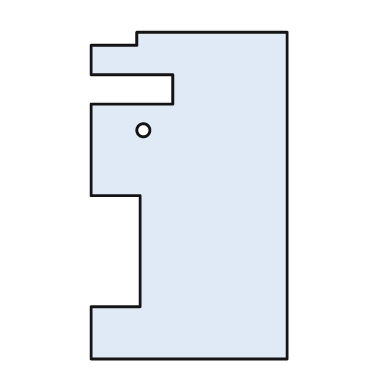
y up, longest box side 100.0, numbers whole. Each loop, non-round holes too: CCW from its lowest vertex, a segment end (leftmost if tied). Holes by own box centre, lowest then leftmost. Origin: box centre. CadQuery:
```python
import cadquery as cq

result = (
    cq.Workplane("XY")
    .moveTo(-30.0, -50.0)
    .lineTo(30.0, -50.0)
    .lineTo(30.0, 50.0)
    .lineTo(-16.0, 50.0)
    .lineTo(-16.0, 46.0)
    .lineTo(-30.0, 46.0)
    .lineTo(-30.0, 37.0)
    .lineTo(-5.0, 37.0)
    .lineTo(-5.0, 28.0)
    .lineTo(-30.0, 28.0)
    .lineTo(-30.0, 0.0)
    .lineTo(-15.0, 0.0)
    .lineTo(-15.0, -34.0)
    .lineTo(-30.0, -34.0)
    .close()
    .moveTo(-14.0, 20.0)
    .circle(2.0)
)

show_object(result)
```